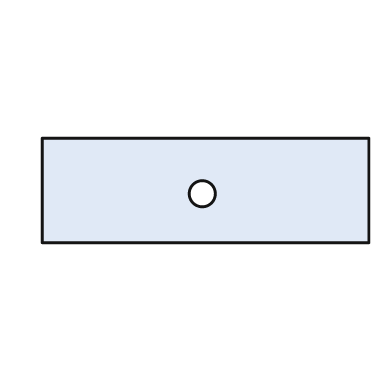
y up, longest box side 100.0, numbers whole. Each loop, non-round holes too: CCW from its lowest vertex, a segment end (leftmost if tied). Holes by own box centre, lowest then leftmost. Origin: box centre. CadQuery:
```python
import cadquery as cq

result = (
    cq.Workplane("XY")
    .moveTo(-50.0, -16.0)
    .lineTo(50.0, -16.0)
    .lineTo(50.0, 16.0)
    .lineTo(-50.0, 16.0)
    .close()
    .moveTo(-1.0, -1.0)
    .circle(4.0)
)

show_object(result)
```